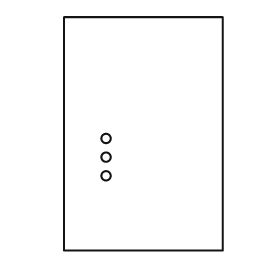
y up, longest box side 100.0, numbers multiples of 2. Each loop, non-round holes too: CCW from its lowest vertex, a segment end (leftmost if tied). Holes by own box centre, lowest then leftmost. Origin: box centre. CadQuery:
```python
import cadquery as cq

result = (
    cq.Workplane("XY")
    .moveTo(-34.0, -50.0)
    .lineTo(34.0, -50.0)
    .lineTo(34.0, 50.0)
    .lineTo(-34.0, 50.0)
    .close()
    .moveTo(-16.0, -18.0)
    .circle(2.0)
    .moveTo(-16.0, -10.0)
    .circle(2.0)
    .moveTo(-16.0, -2.0)
    .circle(2.0)
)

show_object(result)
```